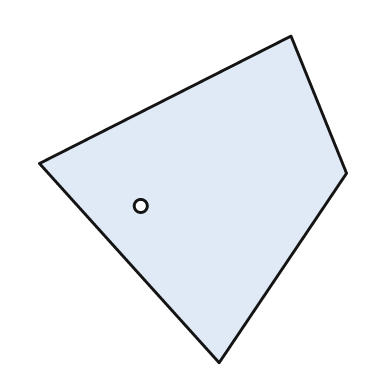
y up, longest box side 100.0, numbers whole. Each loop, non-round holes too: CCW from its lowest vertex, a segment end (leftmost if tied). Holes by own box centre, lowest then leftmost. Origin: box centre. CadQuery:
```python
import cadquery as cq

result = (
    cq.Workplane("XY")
    .moveTo(8.0, -50.0)
    .lineTo(47.0, 8.0)
    .lineTo(30.0, 50.0)
    .lineTo(-47.0, 11.0)
    .close()
    .moveTo(-16.0, -2.0)
    .circle(2.0)
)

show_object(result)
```